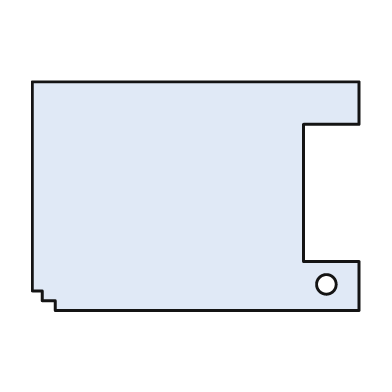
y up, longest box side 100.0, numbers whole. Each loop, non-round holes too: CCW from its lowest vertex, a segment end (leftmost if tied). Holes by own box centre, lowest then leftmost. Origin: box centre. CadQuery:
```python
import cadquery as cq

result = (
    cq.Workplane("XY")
    .moveTo(-43.0, -35.0)
    .lineTo(50.0, -35.0)
    .lineTo(50.0, -20.0)
    .lineTo(33.0, -20.0)
    .lineTo(33.0, 22.0)
    .lineTo(50.0, 22.0)
    .lineTo(50.0, 35.0)
    .lineTo(-50.0, 35.0)
    .lineTo(-50.0, -29.0)
    .lineTo(-47.0, -29.0)
    .lineTo(-47.0, -32.0)
    .lineTo(-43.0, -32.0)
    .close()
    .moveTo(40.0, -27.0)
    .circle(3.0)
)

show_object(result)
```